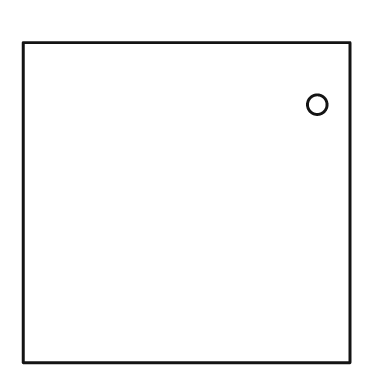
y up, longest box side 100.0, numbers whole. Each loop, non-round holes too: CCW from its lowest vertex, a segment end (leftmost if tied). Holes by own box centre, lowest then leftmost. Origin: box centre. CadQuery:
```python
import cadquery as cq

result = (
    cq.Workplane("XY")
    .moveTo(-50.0, -49.0)
    .lineTo(50.0, -49.0)
    .lineTo(50.0, 49.0)
    .lineTo(-50.0, 49.0)
    .close()
    .moveTo(40.0, 30.0)
    .circle(3.0)
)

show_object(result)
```